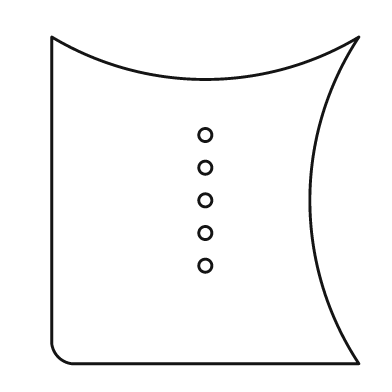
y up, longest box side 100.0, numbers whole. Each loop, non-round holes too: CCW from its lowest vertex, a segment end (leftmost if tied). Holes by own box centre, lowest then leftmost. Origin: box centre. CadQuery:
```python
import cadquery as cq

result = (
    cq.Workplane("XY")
    .moveTo(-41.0, -50.0)
    .lineTo(47.0, -50.0)
    .threePointArc((32.0, 0.0), (47.0, 50.0))
    .threePointArc((0.0, 37.0), (-47.0, 50.0))
    .lineTo(-47.0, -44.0)
    .threePointArc((-45.0, -48.0), (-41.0, -50.0))
    .close()
    .moveTo(0.0, -20.0)
    .circle(2.0)
    .moveTo(0.0, -10.0)
    .circle(2.0)
    .moveTo(0.0, 0.0)
    .circle(2.0)
    .moveTo(0.0, 10.0)
    .circle(2.0)
    .moveTo(0.0, 20.0)
    .circle(2.0)
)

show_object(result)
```